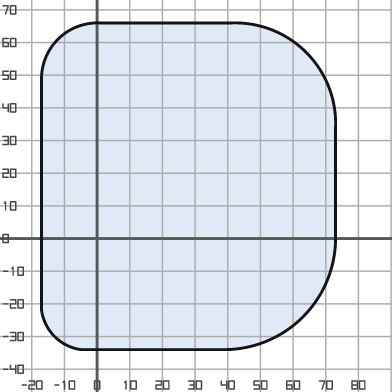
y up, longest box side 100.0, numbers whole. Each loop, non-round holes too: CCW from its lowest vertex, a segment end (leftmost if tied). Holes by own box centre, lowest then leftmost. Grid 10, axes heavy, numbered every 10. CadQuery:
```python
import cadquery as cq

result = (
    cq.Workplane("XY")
    .moveTo(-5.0, -34.0)
    .lineTo(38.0, -34.0)
    .threePointArc((63.0, -24.0), (73.0, 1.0))
    .lineTo(73.0, 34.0)
    .threePointArc((64.0, 57.0), (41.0, 66.0))
    .lineTo(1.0, 66.0)
    .threePointArc((-12.0, 61.0), (-17.0, 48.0))
    .lineTo(-17.0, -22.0)
    .threePointArc((-13.0, -30.0), (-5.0, -34.0))
    .close()
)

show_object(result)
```